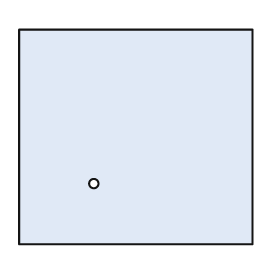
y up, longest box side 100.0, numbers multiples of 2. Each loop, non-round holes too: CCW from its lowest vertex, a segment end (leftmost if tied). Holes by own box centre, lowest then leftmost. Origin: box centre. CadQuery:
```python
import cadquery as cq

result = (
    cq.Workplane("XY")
    .moveTo(-50.0, -46.0)
    .lineTo(50.0, -46.0)
    .lineTo(50.0, 46.0)
    .lineTo(-50.0, 46.0)
    .close()
    .moveTo(-18.0, -20.0)
    .circle(2.0)
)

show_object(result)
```